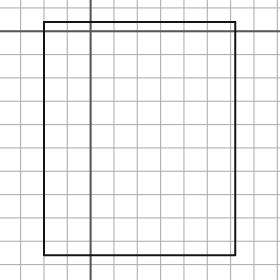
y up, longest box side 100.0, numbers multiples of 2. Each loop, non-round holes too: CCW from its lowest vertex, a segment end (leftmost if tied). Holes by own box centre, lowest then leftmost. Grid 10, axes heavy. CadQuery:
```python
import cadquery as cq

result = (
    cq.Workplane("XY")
    .moveTo(-20.0, -96.0)
    .lineTo(62.0, -96.0)
    .lineTo(62.0, 4.0)
    .lineTo(-20.0, 4.0)
    .close()
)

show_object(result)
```